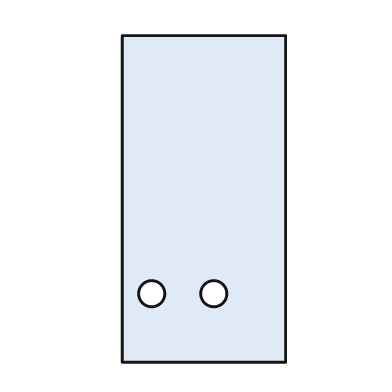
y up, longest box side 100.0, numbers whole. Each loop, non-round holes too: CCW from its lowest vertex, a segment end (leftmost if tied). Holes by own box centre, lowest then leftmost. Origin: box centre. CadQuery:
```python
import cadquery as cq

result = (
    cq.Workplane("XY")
    .moveTo(-25.0, -50.0)
    .lineTo(25.0, -50.0)
    .lineTo(25.0, 50.0)
    .lineTo(-25.0, 50.0)
    .close()
    .moveTo(-16.0, -29.0)
    .circle(4.0)
    .moveTo(3.0, -29.0)
    .circle(4.0)
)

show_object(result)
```